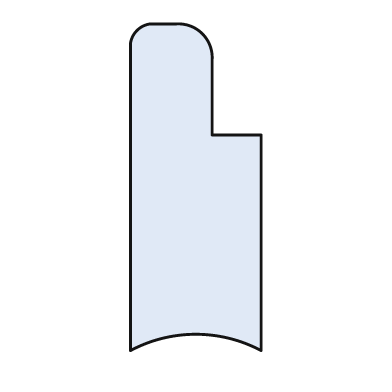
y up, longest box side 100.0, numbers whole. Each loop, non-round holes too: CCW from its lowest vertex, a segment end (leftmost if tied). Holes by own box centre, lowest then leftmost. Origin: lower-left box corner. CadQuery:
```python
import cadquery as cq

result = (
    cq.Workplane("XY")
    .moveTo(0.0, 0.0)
    .threePointArc((20.0, 5.0), (40.0, 0.0))
    .lineTo(40.0, 66.0)
    .lineTo(25.0, 66.0)
    .lineTo(25.0, 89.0)
    .threePointArc((22.0, 97.0), (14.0, 100.0))
    .lineTo(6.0, 100.0)
    .threePointArc((2.0, 98.0), (0.0, 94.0))
    .close()
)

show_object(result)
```